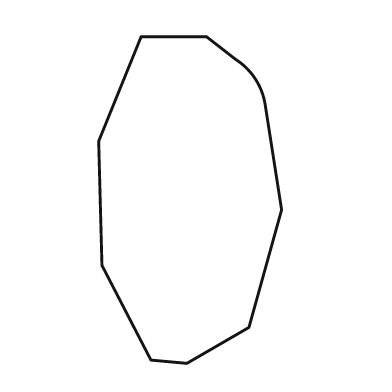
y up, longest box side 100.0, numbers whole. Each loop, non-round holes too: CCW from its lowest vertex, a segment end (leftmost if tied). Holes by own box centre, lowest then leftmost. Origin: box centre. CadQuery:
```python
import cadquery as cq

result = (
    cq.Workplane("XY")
    .moveTo(-1.0, -50.0)
    .lineTo(18.0, -39.0)
    .lineTo(28.0, -3.0)
    .lineTo(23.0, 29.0)
    .threePointArc((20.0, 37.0), (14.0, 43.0))
    .lineTo(5.0, 50.0)
    .lineTo(-15.0, 50.0)
    .lineTo(-28.0, 18.0)
    .lineTo(-27.0, -20.0)
    .lineTo(-12.0, -49.0)
    .close()
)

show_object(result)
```